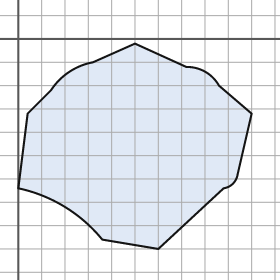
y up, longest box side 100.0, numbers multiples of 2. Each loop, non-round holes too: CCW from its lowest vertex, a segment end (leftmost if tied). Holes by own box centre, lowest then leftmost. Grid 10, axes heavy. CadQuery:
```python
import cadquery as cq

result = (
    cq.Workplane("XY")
    .moveTo(60.0, -90.0)
    .lineTo(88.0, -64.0)
    .threePointArc((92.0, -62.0), (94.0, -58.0))
    .lineTo(100.0, -32.0)
    .lineTo(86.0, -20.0)
    .threePointArc((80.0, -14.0), (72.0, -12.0))
    .lineTo(50.0, -2.0)
    .lineTo(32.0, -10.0)
    .threePointArc((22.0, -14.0), (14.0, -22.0))
    .lineTo(4.0, -32.0)
    .lineTo(0.0, -64.0)
    .threePointArc((20.0, -72.0), (36.0, -86.0))
    .close()
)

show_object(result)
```